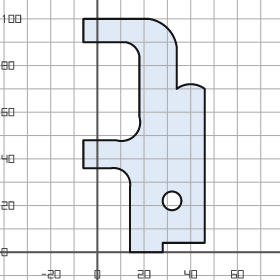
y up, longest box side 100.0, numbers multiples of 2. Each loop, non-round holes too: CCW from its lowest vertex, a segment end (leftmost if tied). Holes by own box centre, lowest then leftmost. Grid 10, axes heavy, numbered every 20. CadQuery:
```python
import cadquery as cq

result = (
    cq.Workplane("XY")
    .moveTo(14.0, 0.0)
    .lineTo(28.0, 0.0)
    .lineTo(28.0, 4.0)
    .lineTo(46.0, 4.0)
    .lineTo(46.0, 70.0)
    .threePointArc((40.0, 72.0), (34.0, 70.0))
    .lineTo(34.0, 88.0)
    .threePointArc((30.0, 96.0), (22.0, 100.0))
    .lineTo(-6.0, 100.0)
    .lineTo(-6.0, 90.0)
    .lineTo(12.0, 90.0)
    .threePointArc((16.0, 88.0), (18.0, 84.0))
    .lineTo(18.0, 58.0)
    .threePointArc((16.0, 50.0), (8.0, 48.0))
    .lineTo(-6.0, 48.0)
    .lineTo(-6.0, 36.0)
    .lineTo(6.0, 36.0)
    .threePointArc((12.0, 34.0), (14.0, 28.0))
    .close()
    .moveTo(32.0, 22.0)
    .circle(4.0)
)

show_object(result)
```